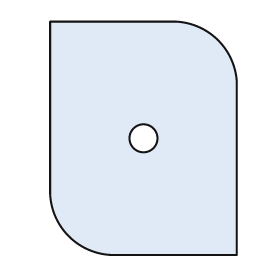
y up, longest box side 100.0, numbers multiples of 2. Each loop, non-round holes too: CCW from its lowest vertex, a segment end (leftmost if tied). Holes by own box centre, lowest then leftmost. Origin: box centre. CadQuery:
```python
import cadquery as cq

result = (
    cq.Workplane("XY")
    .moveTo(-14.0, -50.0)
    .lineTo(40.0, -50.0)
    .lineTo(40.0, 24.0)
    .threePointArc((32.0, 42.0), (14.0, 50.0))
    .lineTo(-40.0, 50.0)
    .lineTo(-40.0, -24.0)
    .threePointArc((-32.0, -42.0), (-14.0, -50.0))
    .close()
    .moveTo(0.0, 0.0)
    .circle(6.0)
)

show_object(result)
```